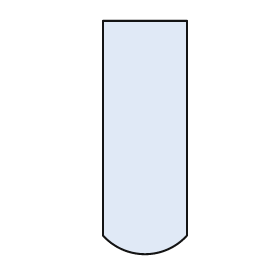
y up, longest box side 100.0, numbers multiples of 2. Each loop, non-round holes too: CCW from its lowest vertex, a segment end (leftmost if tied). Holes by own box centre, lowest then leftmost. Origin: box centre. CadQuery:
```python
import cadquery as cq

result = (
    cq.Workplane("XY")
    .moveTo(-18.0, -42.0)
    .threePointArc((0.0, -50.0), (18.0, -42.0))
    .lineTo(18.0, 50.0)
    .lineTo(-18.0, 50.0)
    .close()
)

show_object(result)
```